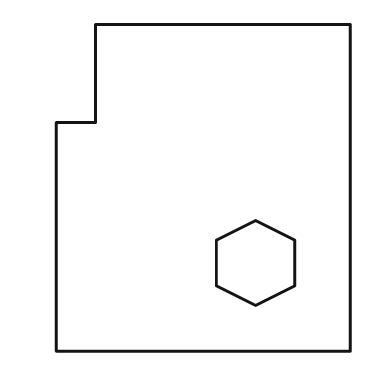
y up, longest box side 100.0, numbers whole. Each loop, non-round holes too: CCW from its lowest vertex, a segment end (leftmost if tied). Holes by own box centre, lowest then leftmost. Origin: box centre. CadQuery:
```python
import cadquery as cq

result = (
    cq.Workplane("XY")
    .moveTo(-45.0, -50.0)
    .lineTo(45.0, -50.0)
    .lineTo(45.0, 50.0)
    .lineTo(-33.0, 50.0)
    .lineTo(-33.0, 20.0)
    .lineTo(-45.0, 20.0)
    .close()
    .moveTo(16.0, -36.0)
    .lineTo(28.0, -30.0)
    .lineTo(28.0, -16.0)
    .lineTo(16.0, -10.0)
    .lineTo(4.0, -16.0)
    .lineTo(4.0, -30.0)
    .close()
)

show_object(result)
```